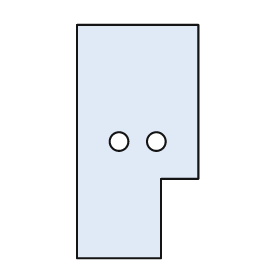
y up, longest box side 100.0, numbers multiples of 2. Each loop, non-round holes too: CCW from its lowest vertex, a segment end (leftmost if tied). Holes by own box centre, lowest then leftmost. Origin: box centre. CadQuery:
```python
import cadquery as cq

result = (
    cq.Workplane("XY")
    .moveTo(-26.0, -50.0)
    .lineTo(10.0, -50.0)
    .lineTo(10.0, -16.0)
    .lineTo(26.0, -16.0)
    .lineTo(26.0, 50.0)
    .lineTo(-26.0, 50.0)
    .close()
    .moveTo(-8.0, 0.0)
    .circle(4.0)
    .moveTo(8.0, 0.0)
    .circle(4.0)
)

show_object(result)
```